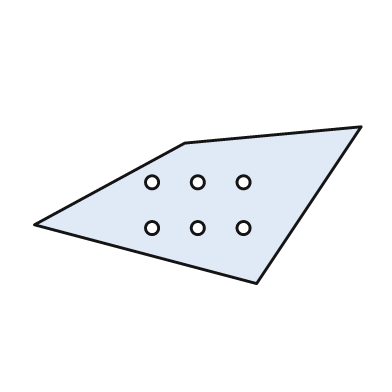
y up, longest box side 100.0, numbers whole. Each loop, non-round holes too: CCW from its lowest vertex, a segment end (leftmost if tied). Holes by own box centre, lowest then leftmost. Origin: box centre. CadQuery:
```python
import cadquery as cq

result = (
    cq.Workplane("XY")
    .moveTo(18.0, -24.0)
    .lineTo(50.0, 24.0)
    .lineTo(-4.0, 19.0)
    .lineTo(-50.0, -6.0)
    .close()
    .moveTo(-14.0, -7.0)
    .circle(2.0)
    .moveTo(0.0, -7.0)
    .circle(2.0)
    .moveTo(14.0, -7.0)
    .circle(2.0)
    .moveTo(-14.0, 7.0)
    .circle(2.0)
    .moveTo(0.0, 7.0)
    .circle(2.0)
    .moveTo(14.0, 7.0)
    .circle(2.0)
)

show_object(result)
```